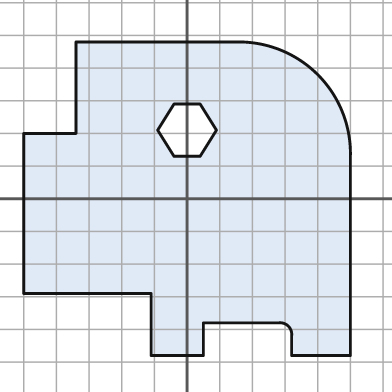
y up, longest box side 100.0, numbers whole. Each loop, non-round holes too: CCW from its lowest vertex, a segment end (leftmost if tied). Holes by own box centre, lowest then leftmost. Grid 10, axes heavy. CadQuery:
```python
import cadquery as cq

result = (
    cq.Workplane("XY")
    .moveTo(-11.0, -48.0)
    .lineTo(5.0, -48.0)
    .lineTo(5.0, -38.0)
    .lineTo(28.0, -38.0)
    .threePointArc((31.0, -39.0), (32.0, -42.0))
    .lineTo(32.0, -48.0)
    .lineTo(50.0, -48.0)
    .lineTo(50.0, 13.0)
    .threePointArc((40.0, 38.0), (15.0, 48.0))
    .lineTo(-34.0, 48.0)
    .lineTo(-34.0, 20.0)
    .lineTo(-50.0, 20.0)
    .lineTo(-50.0, -29.0)
    .lineTo(-11.0, -29.0)
    .close()
    .moveTo(-4.0, 13.0)
    .lineTo(4.0, 13.0)
    .lineTo(9.0, 21.0)
    .lineTo(4.0, 29.0)
    .lineTo(-4.0, 29.0)
    .lineTo(-9.0, 21.0)
    .close()
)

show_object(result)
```